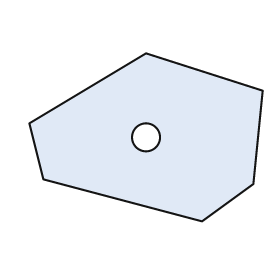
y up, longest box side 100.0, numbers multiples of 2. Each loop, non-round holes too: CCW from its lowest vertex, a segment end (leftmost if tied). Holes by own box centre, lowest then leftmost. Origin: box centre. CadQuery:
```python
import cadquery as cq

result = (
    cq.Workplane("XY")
    .moveTo(24.0, -36.0)
    .lineTo(46.0, -20.0)
    .lineTo(50.0, 20.0)
    .lineTo(0.0, 36.0)
    .lineTo(-50.0, 6.0)
    .lineTo(-44.0, -18.0)
    .close()
    .moveTo(0.0, 0.0)
    .circle(6.0)
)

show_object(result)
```